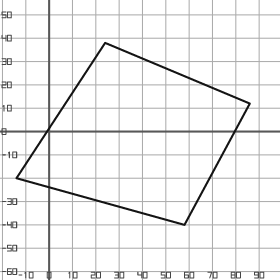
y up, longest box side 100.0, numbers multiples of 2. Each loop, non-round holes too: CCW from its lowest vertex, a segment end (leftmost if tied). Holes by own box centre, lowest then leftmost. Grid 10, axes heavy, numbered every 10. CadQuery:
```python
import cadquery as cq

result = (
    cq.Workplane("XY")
    .moveTo(58.0, -40.0)
    .lineTo(86.0, 12.0)
    .lineTo(24.0, 38.0)
    .lineTo(-14.0, -20.0)
    .close()
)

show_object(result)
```